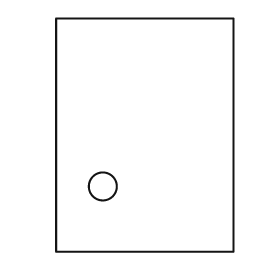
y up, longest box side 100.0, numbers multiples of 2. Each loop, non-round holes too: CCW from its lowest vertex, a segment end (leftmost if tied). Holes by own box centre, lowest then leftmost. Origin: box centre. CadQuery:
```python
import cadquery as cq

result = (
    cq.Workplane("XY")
    .moveTo(-38.0, -50.0)
    .lineTo(38.0, -50.0)
    .lineTo(38.0, 50.0)
    .lineTo(-38.0, 50.0)
    .close()
    .moveTo(-18.0, -22.0)
    .circle(6.0)
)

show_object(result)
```